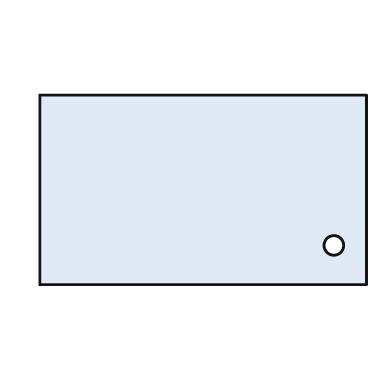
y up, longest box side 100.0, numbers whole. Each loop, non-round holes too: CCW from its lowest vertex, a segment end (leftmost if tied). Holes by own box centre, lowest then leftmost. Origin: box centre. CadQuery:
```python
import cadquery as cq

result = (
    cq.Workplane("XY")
    .moveTo(-50.0, -29.0)
    .lineTo(50.0, -29.0)
    .lineTo(50.0, 29.0)
    .lineTo(-50.0, 29.0)
    .close()
    .moveTo(40.0, -17.0)
    .circle(3.0)
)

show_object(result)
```